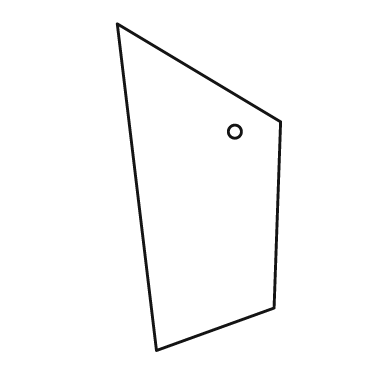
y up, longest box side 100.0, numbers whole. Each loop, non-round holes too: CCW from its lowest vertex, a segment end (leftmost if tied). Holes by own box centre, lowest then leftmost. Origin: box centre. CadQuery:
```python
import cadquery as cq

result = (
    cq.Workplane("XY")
    .moveTo(-13.0, -50.0)
    .lineTo(23.0, -37.0)
    .lineTo(25.0, 20.0)
    .lineTo(-25.0, 50.0)
    .close()
    .moveTo(11.0, 17.0)
    .circle(2.0)
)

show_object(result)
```